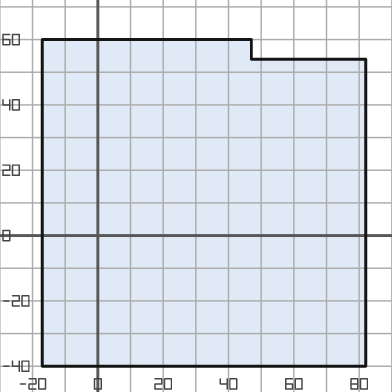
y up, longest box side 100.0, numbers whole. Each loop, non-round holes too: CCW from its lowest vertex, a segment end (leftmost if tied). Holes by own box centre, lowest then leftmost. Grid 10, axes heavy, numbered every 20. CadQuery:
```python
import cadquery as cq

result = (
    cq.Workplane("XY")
    .moveTo(-17.0, -40.0)
    .lineTo(82.0, -40.0)
    .lineTo(82.0, 54.0)
    .lineTo(47.0, 54.0)
    .lineTo(47.0, 60.0)
    .lineTo(-17.0, 60.0)
    .close()
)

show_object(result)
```